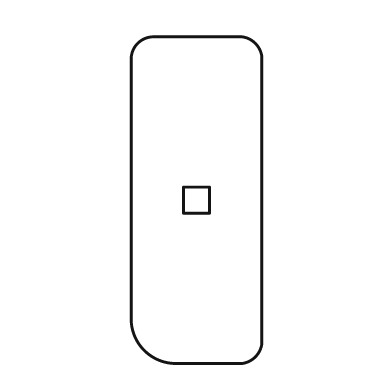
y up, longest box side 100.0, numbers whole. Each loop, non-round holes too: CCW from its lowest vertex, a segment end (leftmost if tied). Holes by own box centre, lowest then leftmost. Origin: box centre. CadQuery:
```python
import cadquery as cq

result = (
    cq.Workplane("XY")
    .moveTo(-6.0, -50.0)
    .lineTo(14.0, -50.0)
    .threePointArc((18.0, -48.0), (20.0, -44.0))
    .lineTo(20.0, 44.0)
    .threePointArc((18.0, 48.0), (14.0, 50.0))
    .lineTo(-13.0, 50.0)
    .threePointArc((-18.0, 48.0), (-20.0, 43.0))
    .lineTo(-20.0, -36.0)
    .threePointArc((-16.0, -46.0), (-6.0, -50.0))
    .close()
    .moveTo(-4.0, -4.0)
    .lineTo(4.0, -4.0)
    .lineTo(4.0, 4.0)
    .lineTo(-4.0, 4.0)
    .close()
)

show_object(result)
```